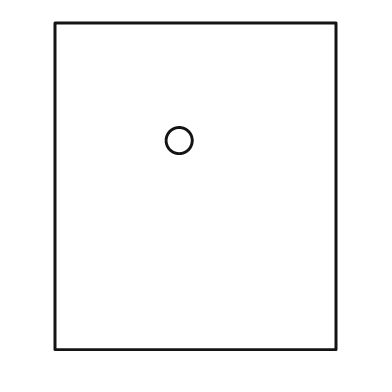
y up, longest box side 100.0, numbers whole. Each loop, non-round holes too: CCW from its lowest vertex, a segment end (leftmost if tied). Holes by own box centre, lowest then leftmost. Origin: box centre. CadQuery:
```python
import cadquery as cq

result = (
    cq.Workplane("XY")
    .moveTo(-43.0, -50.0)
    .lineTo(43.0, -50.0)
    .lineTo(43.0, 50.0)
    .lineTo(-43.0, 50.0)
    .close()
    .moveTo(-5.0, 14.0)
    .circle(4.0)
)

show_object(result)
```